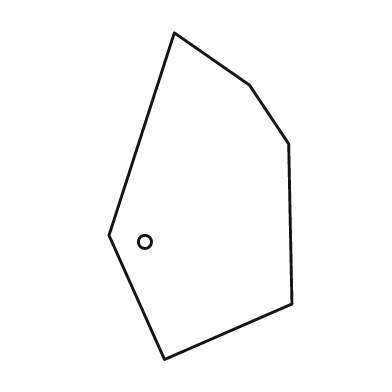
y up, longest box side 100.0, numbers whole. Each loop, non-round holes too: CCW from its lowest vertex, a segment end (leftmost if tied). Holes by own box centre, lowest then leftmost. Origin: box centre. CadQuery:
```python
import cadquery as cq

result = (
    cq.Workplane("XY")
    .moveTo(-11.0, -50.0)
    .lineTo(28.0, -33.0)
    .lineTo(27.0, 16.0)
    .lineTo(15.0, 34.0)
    .lineTo(-8.0, 50.0)
    .lineTo(-28.0, -12.0)
    .close()
    .moveTo(-17.0, -14.0)
    .circle(2.0)
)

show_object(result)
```